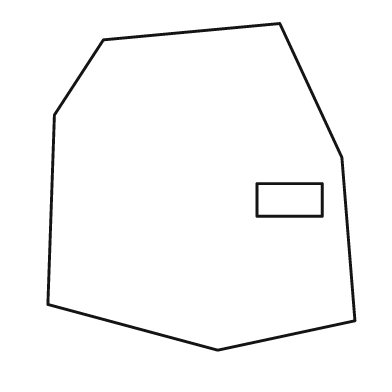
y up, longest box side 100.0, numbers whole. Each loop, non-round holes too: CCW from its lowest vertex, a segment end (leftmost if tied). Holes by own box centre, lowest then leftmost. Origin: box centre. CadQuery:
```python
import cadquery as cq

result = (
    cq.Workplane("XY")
    .moveTo(5.0, -50.0)
    .lineTo(47.0, -41.0)
    .lineTo(43.0, 9.0)
    .lineTo(24.0, 50.0)
    .lineTo(-30.0, 45.0)
    .lineTo(-45.0, 22.0)
    .lineTo(-47.0, -36.0)
    .close()
    .moveTo(17.0, -9.0)
    .lineTo(37.0, -9.0)
    .lineTo(37.0, 1.0)
    .lineTo(17.0, 1.0)
    .close()
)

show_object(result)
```